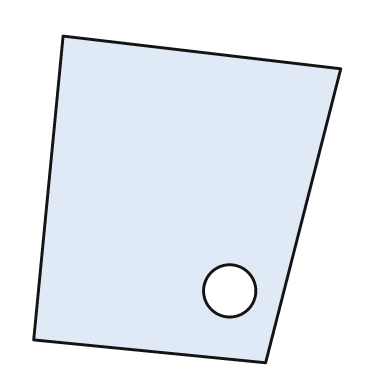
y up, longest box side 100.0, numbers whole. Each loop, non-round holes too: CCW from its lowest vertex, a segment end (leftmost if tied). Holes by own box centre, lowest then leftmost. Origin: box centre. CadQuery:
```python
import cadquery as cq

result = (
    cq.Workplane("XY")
    .moveTo(24.0, -50.0)
    .lineTo(47.0, 40.0)
    .lineTo(-38.0, 50.0)
    .lineTo(-47.0, -43.0)
    .close()
    .moveTo(13.0, -28.0)
    .circle(8.0)
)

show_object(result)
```